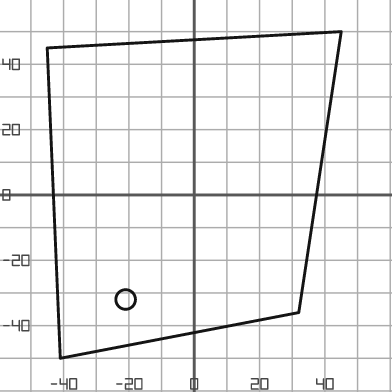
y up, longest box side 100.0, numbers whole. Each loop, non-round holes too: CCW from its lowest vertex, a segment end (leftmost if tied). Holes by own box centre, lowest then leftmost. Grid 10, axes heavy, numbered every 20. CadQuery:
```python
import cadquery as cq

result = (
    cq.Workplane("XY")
    .moveTo(-41.0, -50.0)
    .lineTo(32.0, -36.0)
    .lineTo(45.0, 50.0)
    .lineTo(-45.0, 45.0)
    .close()
    .moveTo(-21.0, -32.0)
    .circle(3.0)
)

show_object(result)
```